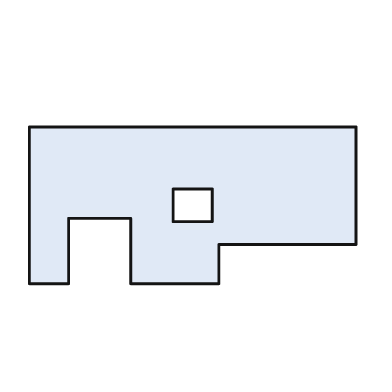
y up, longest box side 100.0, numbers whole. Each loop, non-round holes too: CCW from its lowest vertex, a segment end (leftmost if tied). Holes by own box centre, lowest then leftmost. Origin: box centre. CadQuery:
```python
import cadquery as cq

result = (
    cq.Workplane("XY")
    .moveTo(-50.0, -24.0)
    .lineTo(-38.0, -24.0)
    .lineTo(-38.0, -4.0)
    .lineTo(-19.0, -4.0)
    .lineTo(-19.0, -24.0)
    .lineTo(8.0, -24.0)
    .lineTo(8.0, -12.0)
    .lineTo(50.0, -12.0)
    .lineTo(50.0, 24.0)
    .lineTo(-50.0, 24.0)
    .close()
    .moveTo(-6.0, -5.0)
    .lineTo(6.0, -5.0)
    .lineTo(6.0, 5.0)
    .lineTo(-6.0, 5.0)
    .close()
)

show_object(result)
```